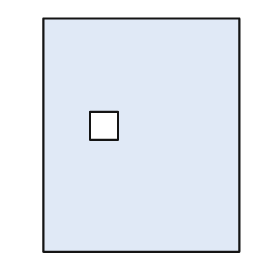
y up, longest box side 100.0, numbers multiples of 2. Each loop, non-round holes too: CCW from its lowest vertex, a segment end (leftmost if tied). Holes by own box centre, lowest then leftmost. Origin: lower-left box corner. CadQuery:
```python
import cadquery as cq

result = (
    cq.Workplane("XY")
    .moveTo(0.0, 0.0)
    .lineTo(84.0, 0.0)
    .lineTo(84.0, 100.0)
    .lineTo(0.0, 100.0)
    .close()
    .moveTo(20.0, 48.0)
    .lineTo(32.0, 48.0)
    .lineTo(32.0, 60.0)
    .lineTo(20.0, 60.0)
    .close()
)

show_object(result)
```